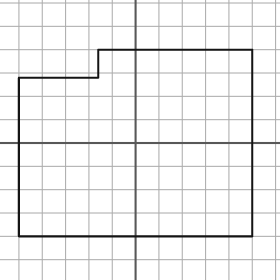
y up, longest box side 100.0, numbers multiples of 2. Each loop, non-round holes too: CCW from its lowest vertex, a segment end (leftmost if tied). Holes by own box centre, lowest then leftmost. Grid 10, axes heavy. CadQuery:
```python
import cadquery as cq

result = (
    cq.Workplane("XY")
    .moveTo(-50.0, -40.0)
    .lineTo(50.0, -40.0)
    .lineTo(50.0, 40.0)
    .lineTo(-16.0, 40.0)
    .lineTo(-16.0, 28.0)
    .lineTo(-50.0, 28.0)
    .close()
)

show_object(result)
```